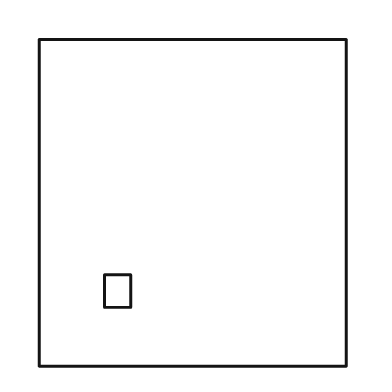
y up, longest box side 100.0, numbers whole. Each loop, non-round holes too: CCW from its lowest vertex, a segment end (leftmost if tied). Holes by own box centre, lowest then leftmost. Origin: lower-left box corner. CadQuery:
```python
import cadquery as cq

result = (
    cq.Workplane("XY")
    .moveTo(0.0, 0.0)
    .lineTo(94.0, 0.0)
    .lineTo(94.0, 100.0)
    .lineTo(0.0, 100.0)
    .close()
    .moveTo(20.0, 18.0)
    .lineTo(28.0, 18.0)
    .lineTo(28.0, 28.0)
    .lineTo(20.0, 28.0)
    .close()
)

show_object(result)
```